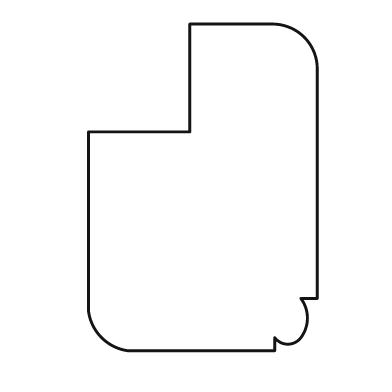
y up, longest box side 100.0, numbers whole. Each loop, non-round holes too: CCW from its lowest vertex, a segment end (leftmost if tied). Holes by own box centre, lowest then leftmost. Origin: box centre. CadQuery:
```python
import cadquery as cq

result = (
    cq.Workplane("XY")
    .moveTo(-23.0, -50.0)
    .lineTo(22.0, -50.0)
    .lineTo(22.0, -46.0)
    .threePointArc((26.0, -48.0), (30.0, -46.0))
    .threePointArc((32.0, -40.0), (30.0, -34.0))
    .lineTo(35.0, -34.0)
    .lineTo(35.0, 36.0)
    .threePointArc((31.0, 46.0), (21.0, 50.0))
    .lineTo(-4.0, 50.0)
    .lineTo(-4.0, 17.0)
    .lineTo(-35.0, 17.0)
    .lineTo(-35.0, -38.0)
    .threePointArc((-31.0, -46.0), (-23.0, -50.0))
    .close()
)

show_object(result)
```